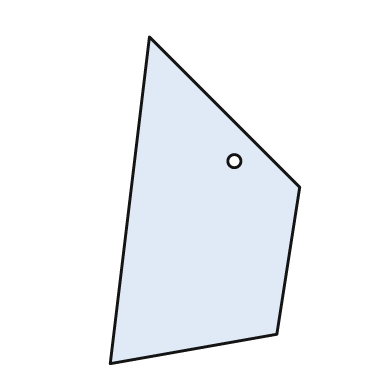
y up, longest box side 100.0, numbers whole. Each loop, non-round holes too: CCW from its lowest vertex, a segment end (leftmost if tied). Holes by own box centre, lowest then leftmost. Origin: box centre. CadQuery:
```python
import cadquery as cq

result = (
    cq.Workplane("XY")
    .moveTo(-29.0, -50.0)
    .lineTo(22.0, -41.0)
    .lineTo(29.0, 4.0)
    .lineTo(-17.0, 50.0)
    .close()
    .moveTo(9.0, 12.0)
    .circle(2.0)
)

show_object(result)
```